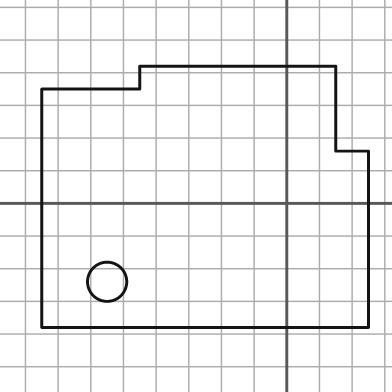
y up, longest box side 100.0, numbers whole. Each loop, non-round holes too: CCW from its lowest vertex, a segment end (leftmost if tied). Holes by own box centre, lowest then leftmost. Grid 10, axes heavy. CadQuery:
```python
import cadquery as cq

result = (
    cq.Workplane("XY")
    .moveTo(-75.0, -38.0)
    .lineTo(25.0, -38.0)
    .lineTo(25.0, 16.0)
    .lineTo(15.0, 16.0)
    .lineTo(15.0, 42.0)
    .lineTo(-45.0, 42.0)
    .lineTo(-45.0, 35.0)
    .lineTo(-75.0, 35.0)
    .close()
    .moveTo(-55.0, -24.0)
    .circle(6.0)
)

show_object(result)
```